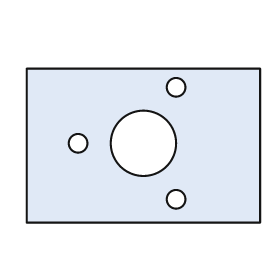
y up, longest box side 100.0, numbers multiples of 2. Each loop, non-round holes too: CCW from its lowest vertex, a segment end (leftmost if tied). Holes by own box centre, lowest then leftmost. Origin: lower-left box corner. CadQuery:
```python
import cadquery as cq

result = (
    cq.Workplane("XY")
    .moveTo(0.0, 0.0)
    .lineTo(100.0, 0.0)
    .lineTo(100.0, 66.0)
    .lineTo(0.0, 66.0)
    .close()
    .moveTo(64.0, 10.0)
    .circle(4.0)
    .moveTo(22.0, 34.0)
    .circle(4.0)
    .moveTo(50.0, 34.0)
    .circle(14.0)
    .moveTo(64.0, 58.0)
    .circle(4.0)
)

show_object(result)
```